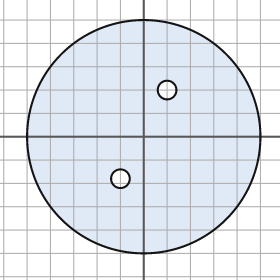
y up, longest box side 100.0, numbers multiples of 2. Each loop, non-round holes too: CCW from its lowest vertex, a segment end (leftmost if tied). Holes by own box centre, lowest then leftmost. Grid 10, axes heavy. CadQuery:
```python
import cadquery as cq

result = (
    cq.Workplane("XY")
    .moveTo(0.0, 0.0)
    .circle(50.0)
    .moveTo(-10.0, -18.0)
    .circle(4.0)
    .moveTo(10.0, 20.0)
    .circle(4.0)
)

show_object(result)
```